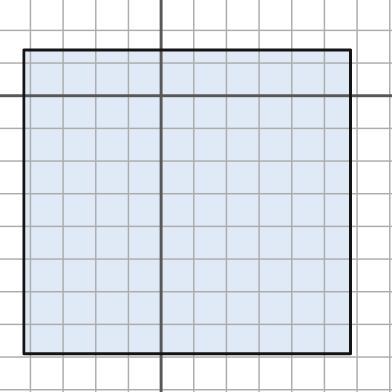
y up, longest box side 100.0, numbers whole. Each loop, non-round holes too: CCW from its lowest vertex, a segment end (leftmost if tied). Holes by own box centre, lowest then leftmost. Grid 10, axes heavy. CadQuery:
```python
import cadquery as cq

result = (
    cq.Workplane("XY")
    .moveTo(-42.0, -79.0)
    .lineTo(58.0, -79.0)
    .lineTo(58.0, 14.0)
    .lineTo(-42.0, 14.0)
    .close()
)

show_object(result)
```